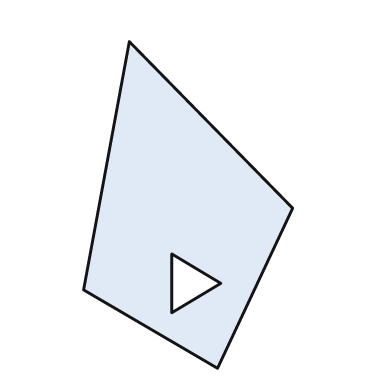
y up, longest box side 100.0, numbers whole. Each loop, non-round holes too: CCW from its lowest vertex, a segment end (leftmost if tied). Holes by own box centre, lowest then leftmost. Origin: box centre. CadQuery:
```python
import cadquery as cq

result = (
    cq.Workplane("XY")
    .moveTo(9.0, -50.0)
    .lineTo(32.0, -1.0)
    .lineTo(-18.0, 50.0)
    .lineTo(-32.0, -26.0)
    .close()
    .moveTo(-5.0, -33.0)
    .lineTo(10.0, -24.0)
    .lineTo(-5.0, -15.0)
    .close()
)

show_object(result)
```